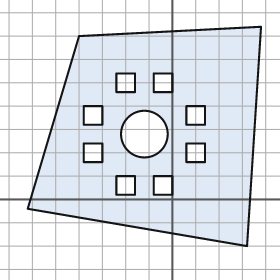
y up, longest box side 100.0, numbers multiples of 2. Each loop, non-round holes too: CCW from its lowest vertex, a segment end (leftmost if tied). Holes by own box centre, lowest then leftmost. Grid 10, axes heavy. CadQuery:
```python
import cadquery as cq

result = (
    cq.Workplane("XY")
    .moveTo(32.0, -20.0)
    .lineTo(38.0, 74.0)
    .lineTo(-40.0, 70.0)
    .lineTo(-62.0, -4.0)
    .close()
    .moveTo(-24.0, 2.0)
    .lineTo(-16.0, 2.0)
    .lineTo(-16.0, 10.0)
    .lineTo(-24.0, 10.0)
    .close()
    .moveTo(-8.0, 2.0)
    .lineTo(0.0, 2.0)
    .lineTo(0.0, 10.0)
    .lineTo(-8.0, 10.0)
    .close()
    .moveTo(-38.0, 16.0)
    .lineTo(-30.0, 16.0)
    .lineTo(-30.0, 24.0)
    .lineTo(-38.0, 24.0)
    .close()
    .moveTo(6.0, 16.0)
    .lineTo(14.0, 16.0)
    .lineTo(14.0, 24.0)
    .lineTo(6.0, 24.0)
    .close()
    .moveTo(-12.0, 28.0)
    .circle(10.0)
    .moveTo(-38.0, 32.0)
    .lineTo(-30.0, 32.0)
    .lineTo(-30.0, 40.0)
    .lineTo(-38.0, 40.0)
    .close()
    .moveTo(6.0, 32.0)
    .lineTo(14.0, 32.0)
    .lineTo(14.0, 40.0)
    .lineTo(6.0, 40.0)
    .close()
    .moveTo(-24.0, 46.0)
    .lineTo(-16.0, 46.0)
    .lineTo(-16.0, 54.0)
    .lineTo(-24.0, 54.0)
    .close()
    .moveTo(-8.0, 46.0)
    .lineTo(0.0, 46.0)
    .lineTo(0.0, 54.0)
    .lineTo(-8.0, 54.0)
    .close()
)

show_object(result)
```